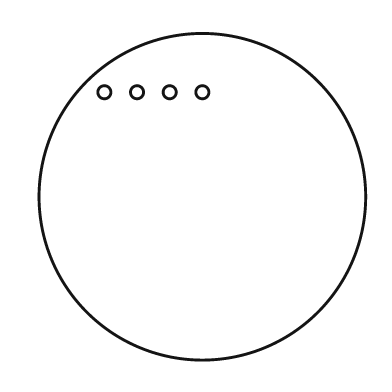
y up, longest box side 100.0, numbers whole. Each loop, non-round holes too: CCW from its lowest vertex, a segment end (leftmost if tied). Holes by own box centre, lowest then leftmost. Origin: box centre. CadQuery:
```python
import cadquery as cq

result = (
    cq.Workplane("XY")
    .moveTo(0.0, 0.0)
    .circle(50.0)
    .moveTo(-30.0, 32.0)
    .circle(2.0)
    .moveTo(-20.0, 32.0)
    .circle(2.0)
    .moveTo(-10.0, 32.0)
    .circle(2.0)
    .moveTo(0.0, 32.0)
    .circle(2.0)
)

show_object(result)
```